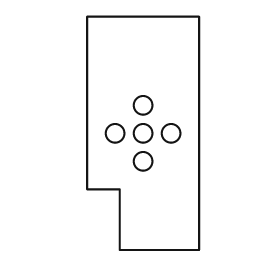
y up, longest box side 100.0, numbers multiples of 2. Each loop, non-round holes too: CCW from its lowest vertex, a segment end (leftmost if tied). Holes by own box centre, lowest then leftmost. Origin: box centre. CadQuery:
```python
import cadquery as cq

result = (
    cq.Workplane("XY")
    .moveTo(-10.0, -50.0)
    .lineTo(24.0, -50.0)
    .lineTo(24.0, 50.0)
    .lineTo(-24.0, 50.0)
    .lineTo(-24.0, -24.0)
    .lineTo(-10.0, -24.0)
    .close()
    .moveTo(0.0, -12.0)
    .circle(4.0)
    .moveTo(-12.0, 0.0)
    .circle(4.0)
    .moveTo(0.0, 0.0)
    .circle(4.0)
    .moveTo(12.0, 0.0)
    .circle(4.0)
    .moveTo(0.0, 12.0)
    .circle(4.0)
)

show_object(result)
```